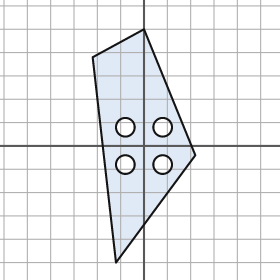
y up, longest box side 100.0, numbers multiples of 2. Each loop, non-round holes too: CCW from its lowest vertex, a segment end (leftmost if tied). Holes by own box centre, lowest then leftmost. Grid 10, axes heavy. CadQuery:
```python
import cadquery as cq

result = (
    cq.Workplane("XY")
    .moveTo(-12.0, -50.0)
    .lineTo(22.0, -4.0)
    .lineTo(0.0, 50.0)
    .lineTo(-22.0, 38.0)
    .close()
    .moveTo(-8.0, -8.0)
    .circle(4.0)
    .moveTo(8.0, -8.0)
    .circle(4.0)
    .moveTo(-8.0, 8.0)
    .circle(4.0)
    .moveTo(8.0, 8.0)
    .circle(4.0)
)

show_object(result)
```